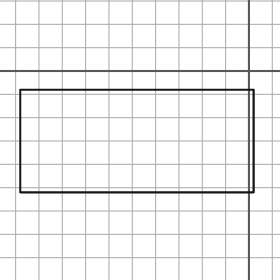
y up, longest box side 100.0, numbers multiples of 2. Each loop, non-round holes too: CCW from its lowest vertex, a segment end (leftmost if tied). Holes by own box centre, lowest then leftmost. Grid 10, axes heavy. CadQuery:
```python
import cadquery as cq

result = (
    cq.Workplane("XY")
    .moveTo(-98.0, -52.0)
    .lineTo(2.0, -52.0)
    .lineTo(2.0, -8.0)
    .lineTo(-98.0, -8.0)
    .close()
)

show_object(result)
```